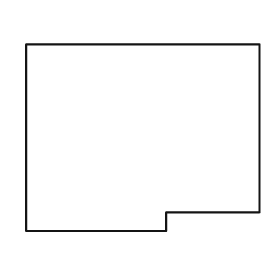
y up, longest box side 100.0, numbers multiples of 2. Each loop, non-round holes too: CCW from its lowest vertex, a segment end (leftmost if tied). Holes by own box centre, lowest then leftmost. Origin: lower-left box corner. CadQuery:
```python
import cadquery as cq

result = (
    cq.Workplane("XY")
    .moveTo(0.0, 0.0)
    .lineTo(60.0, 0.0)
    .lineTo(60.0, 8.0)
    .lineTo(100.0, 8.0)
    .lineTo(100.0, 80.0)
    .lineTo(0.0, 80.0)
    .close()
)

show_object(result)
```